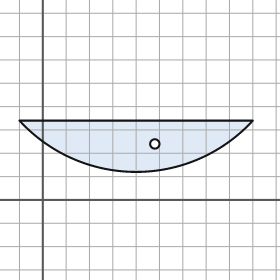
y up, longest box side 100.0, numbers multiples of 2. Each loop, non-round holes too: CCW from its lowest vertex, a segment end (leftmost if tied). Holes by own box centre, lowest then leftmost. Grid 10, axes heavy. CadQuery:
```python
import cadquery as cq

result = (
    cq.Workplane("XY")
    .moveTo(-10.0, 34.0)
    .threePointArc((40.0, 12.0), (90.0, 34.0))
    .close()
    .moveTo(48.0, 24.0)
    .circle(2.0)
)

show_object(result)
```